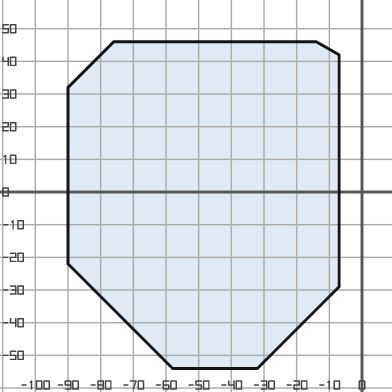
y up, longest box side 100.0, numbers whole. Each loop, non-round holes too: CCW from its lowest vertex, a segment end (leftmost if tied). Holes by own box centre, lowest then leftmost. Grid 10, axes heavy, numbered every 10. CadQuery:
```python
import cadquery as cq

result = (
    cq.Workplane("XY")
    .moveTo(-58.0, -54.0)
    .lineTo(-32.0, -54.0)
    .lineTo(-7.0, -29.0)
    .lineTo(-7.0, 42.0)
    .lineTo(-14.0, 46.0)
    .lineTo(-76.0, 46.0)
    .lineTo(-90.0, 32.0)
    .lineTo(-90.0, -22.0)
    .close()
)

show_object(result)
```